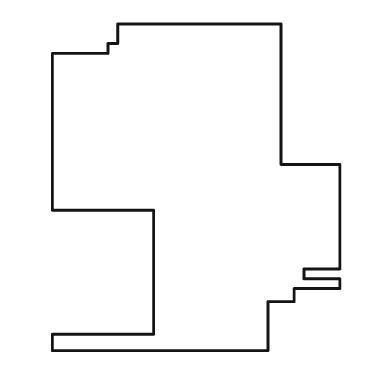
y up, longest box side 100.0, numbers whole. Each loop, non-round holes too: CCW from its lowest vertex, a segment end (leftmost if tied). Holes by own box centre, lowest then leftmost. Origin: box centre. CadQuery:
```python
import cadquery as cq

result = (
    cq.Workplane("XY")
    .moveTo(-44.0, -50.0)
    .lineTo(22.0, -50.0)
    .lineTo(22.0, -35.0)
    .lineTo(30.0, -35.0)
    .lineTo(30.0, -31.0)
    .lineTo(44.0, -31.0)
    .lineTo(44.0, -28.0)
    .lineTo(33.0, -28.0)
    .lineTo(33.0, -25.0)
    .lineTo(44.0, -25.0)
    .lineTo(44.0, 7.0)
    .lineTo(26.0, 7.0)
    .lineTo(26.0, 50.0)
    .lineTo(-24.0, 50.0)
    .lineTo(-24.0, 44.0)
    .lineTo(-27.0, 44.0)
    .lineTo(-27.0, 41.0)
    .lineTo(-44.0, 41.0)
    .lineTo(-44.0, -7.0)
    .lineTo(-13.0, -7.0)
    .lineTo(-13.0, -45.0)
    .lineTo(-44.0, -45.0)
    .close()
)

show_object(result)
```